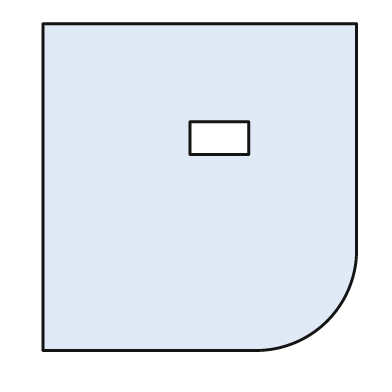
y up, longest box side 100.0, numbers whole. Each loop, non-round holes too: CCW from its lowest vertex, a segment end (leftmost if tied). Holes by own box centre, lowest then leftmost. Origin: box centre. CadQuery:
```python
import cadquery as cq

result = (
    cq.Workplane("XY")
    .moveTo(-48.0, -50.0)
    .lineTo(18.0, -50.0)
    .threePointArc((39.0, -41.0), (48.0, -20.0))
    .lineTo(48.0, 50.0)
    .lineTo(-48.0, 50.0)
    .close()
    .moveTo(-3.0, 10.0)
    .lineTo(15.0, 10.0)
    .lineTo(15.0, 20.0)
    .lineTo(-3.0, 20.0)
    .close()
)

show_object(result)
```